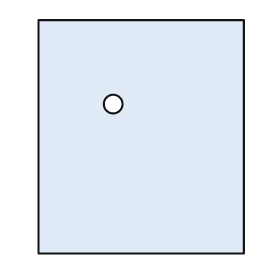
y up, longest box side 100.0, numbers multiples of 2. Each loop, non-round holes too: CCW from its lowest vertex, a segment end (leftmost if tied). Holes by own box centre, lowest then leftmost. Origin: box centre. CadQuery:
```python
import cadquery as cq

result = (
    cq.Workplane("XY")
    .moveTo(-44.0, -50.0)
    .lineTo(44.0, -50.0)
    .lineTo(44.0, 50.0)
    .lineTo(-44.0, 50.0)
    .close()
    .moveTo(-12.0, 14.0)
    .circle(4.0)
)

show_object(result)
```